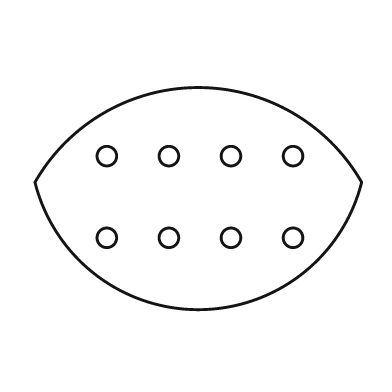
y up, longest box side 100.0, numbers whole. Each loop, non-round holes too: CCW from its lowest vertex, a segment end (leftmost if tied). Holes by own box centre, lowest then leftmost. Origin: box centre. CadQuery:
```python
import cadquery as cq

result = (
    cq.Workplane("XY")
    .moveTo(-50.0, 5.0)
    .threePointArc((0.0, -34.0), (50.0, 5.0))
    .threePointArc((0.0, 34.0), (-50.0, 5.0))
    .close()
    .moveTo(-28.0, -12.0)
    .circle(3.0)
    .moveTo(-9.0, -12.0)
    .circle(3.0)
    .moveTo(10.0, -12.0)
    .circle(3.0)
    .moveTo(29.0, -12.0)
    .circle(3.0)
    .moveTo(-28.0, 13.0)
    .circle(3.0)
    .moveTo(-9.0, 13.0)
    .circle(3.0)
    .moveTo(10.0, 13.0)
    .circle(3.0)
    .moveTo(29.0, 13.0)
    .circle(3.0)
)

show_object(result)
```